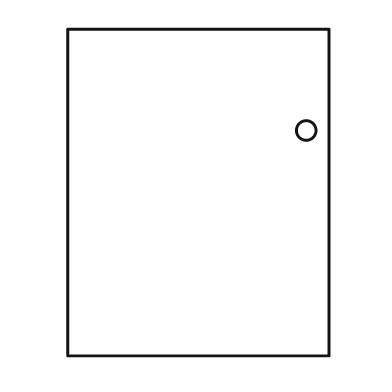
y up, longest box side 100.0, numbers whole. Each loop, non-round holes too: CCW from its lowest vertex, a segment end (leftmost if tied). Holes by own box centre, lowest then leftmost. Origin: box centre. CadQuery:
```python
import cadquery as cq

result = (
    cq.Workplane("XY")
    .moveTo(-40.0, -50.0)
    .lineTo(40.0, -50.0)
    .lineTo(40.0, 50.0)
    .lineTo(-40.0, 50.0)
    .close()
    .moveTo(33.0, 19.0)
    .circle(3.0)
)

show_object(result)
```